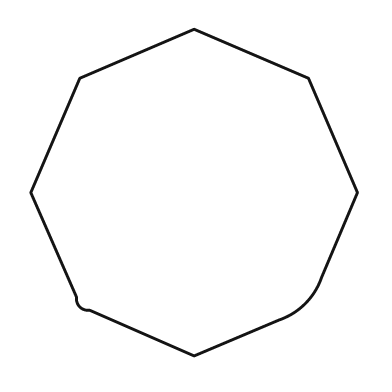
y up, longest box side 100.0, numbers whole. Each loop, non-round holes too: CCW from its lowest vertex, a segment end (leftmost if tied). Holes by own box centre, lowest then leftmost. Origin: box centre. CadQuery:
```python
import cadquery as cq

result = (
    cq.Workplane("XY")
    .moveTo(0.0, -50.0)
    .lineTo(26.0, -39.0)
    .threePointArc((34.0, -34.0), (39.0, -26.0))
    .lineTo(50.0, 0.0)
    .lineTo(35.0, 35.0)
    .lineTo(0.0, 50.0)
    .lineTo(-35.0, 35.0)
    .lineTo(-50.0, 0.0)
    .lineTo(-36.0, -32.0)
    .threePointArc((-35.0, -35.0), (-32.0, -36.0))
    .close()
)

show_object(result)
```